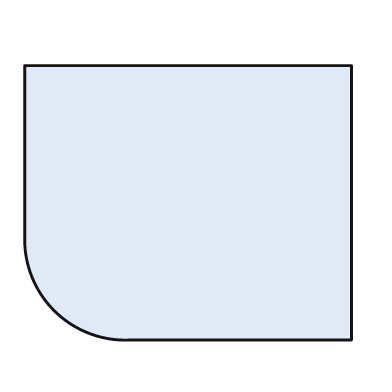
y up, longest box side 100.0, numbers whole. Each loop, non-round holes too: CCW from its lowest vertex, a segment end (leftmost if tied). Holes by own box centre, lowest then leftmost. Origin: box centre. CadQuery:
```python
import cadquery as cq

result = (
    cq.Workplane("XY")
    .moveTo(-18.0, -42.0)
    .lineTo(50.0, -42.0)
    .lineTo(50.0, 42.0)
    .lineTo(-50.0, 42.0)
    .lineTo(-50.0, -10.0)
    .threePointArc((-41.0, -33.0), (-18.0, -42.0))
    .close()
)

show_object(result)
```